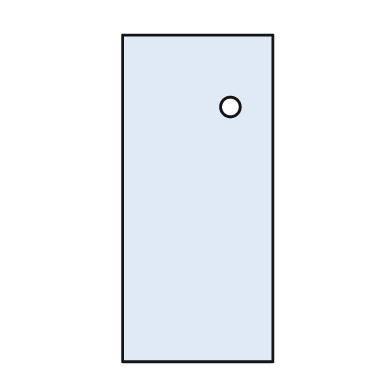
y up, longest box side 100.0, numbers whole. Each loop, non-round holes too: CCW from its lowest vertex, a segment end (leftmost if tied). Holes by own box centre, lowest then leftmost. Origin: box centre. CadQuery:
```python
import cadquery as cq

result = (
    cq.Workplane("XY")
    .moveTo(-23.0, -50.0)
    .lineTo(23.0, -50.0)
    .lineTo(23.0, 50.0)
    .lineTo(-23.0, 50.0)
    .close()
    .moveTo(10.0, 28.0)
    .circle(3.0)
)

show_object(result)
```